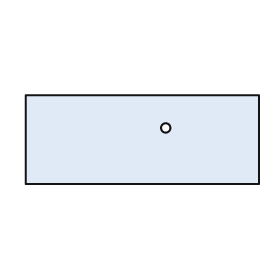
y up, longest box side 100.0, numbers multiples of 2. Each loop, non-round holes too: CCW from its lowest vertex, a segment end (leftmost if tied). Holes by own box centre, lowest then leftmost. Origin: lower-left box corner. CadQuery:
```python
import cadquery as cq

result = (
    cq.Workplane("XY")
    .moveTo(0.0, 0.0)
    .lineTo(100.0, 0.0)
    .lineTo(100.0, 38.0)
    .lineTo(0.0, 38.0)
    .close()
    .moveTo(60.0, 24.0)
    .circle(2.0)
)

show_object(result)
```